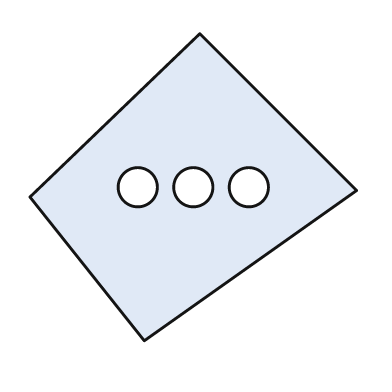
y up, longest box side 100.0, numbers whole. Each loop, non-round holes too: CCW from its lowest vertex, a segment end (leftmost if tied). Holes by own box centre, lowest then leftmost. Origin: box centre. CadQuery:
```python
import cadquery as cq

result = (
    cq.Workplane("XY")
    .moveTo(-15.0, -47.0)
    .lineTo(50.0, -1.0)
    .lineTo(2.0, 47.0)
    .lineTo(-50.0, -3.0)
    .close()
    .moveTo(-17.0, 0.0)
    .circle(6.0)
    .moveTo(0.0, 0.0)
    .circle(6.0)
    .moveTo(17.0, 0.0)
    .circle(6.0)
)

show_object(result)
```